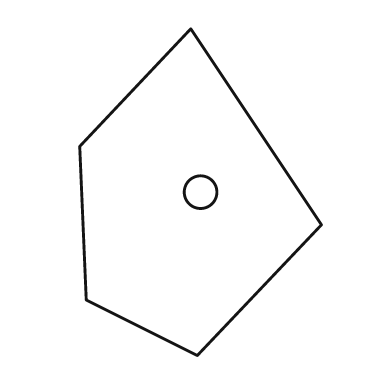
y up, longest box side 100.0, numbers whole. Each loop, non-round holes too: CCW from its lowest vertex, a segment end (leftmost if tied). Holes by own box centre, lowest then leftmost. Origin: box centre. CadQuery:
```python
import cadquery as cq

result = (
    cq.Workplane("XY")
    .moveTo(-1.0, -50.0)
    .lineTo(37.0, -10.0)
    .lineTo(-3.0, 50.0)
    .lineTo(-37.0, 14.0)
    .lineTo(-35.0, -33.0)
    .close()
    .moveTo(0.0, 0.0)
    .circle(5.0)
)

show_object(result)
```